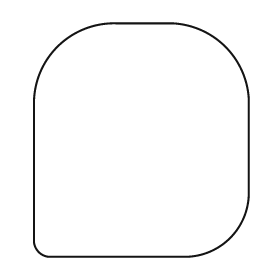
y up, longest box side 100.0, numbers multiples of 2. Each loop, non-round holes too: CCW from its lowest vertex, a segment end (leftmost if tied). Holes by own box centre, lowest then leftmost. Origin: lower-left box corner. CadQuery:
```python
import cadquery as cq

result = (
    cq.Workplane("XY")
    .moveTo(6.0, 0.0)
    .lineTo(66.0, 0.0)
    .threePointArc((84.0, 8.0), (92.0, 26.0))
    .lineTo(92.0, 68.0)
    .threePointArc((82.0, 90.0), (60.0, 100.0))
    .lineTo(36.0, 100.0)
    .threePointArc((10.0, 90.0), (0.0, 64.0))
    .lineTo(0.0, 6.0)
    .threePointArc((2.0, 2.0), (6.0, 0.0))
    .close()
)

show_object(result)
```